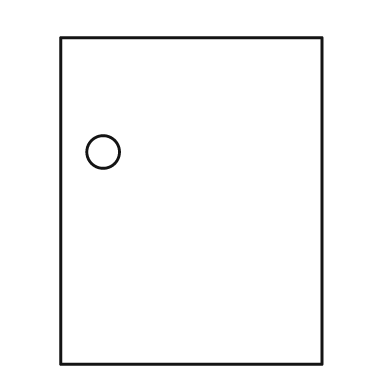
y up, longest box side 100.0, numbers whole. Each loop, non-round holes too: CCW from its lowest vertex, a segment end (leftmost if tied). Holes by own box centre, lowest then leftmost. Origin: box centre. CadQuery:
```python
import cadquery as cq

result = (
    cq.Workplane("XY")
    .moveTo(-40.0, -50.0)
    .lineTo(40.0, -50.0)
    .lineTo(40.0, 50.0)
    .lineTo(-40.0, 50.0)
    .close()
    .moveTo(-27.0, 15.0)
    .circle(5.0)
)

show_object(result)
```